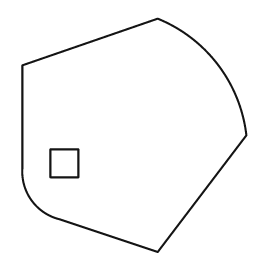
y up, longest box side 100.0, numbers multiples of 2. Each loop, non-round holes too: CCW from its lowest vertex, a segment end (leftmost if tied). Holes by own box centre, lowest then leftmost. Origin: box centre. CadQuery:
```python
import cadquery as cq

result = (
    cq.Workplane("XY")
    .moveTo(10.0, -50.0)
    .lineTo(48.0, 0.0)
    .threePointArc((36.0, 30.0), (10.0, 50.0))
    .lineTo(-48.0, 30.0)
    .lineTo(-48.0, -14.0)
    .threePointArc((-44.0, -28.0), (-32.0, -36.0))
    .close()
    .moveTo(-36.0, -18.0)
    .lineTo(-24.0, -18.0)
    .lineTo(-24.0, -6.0)
    .lineTo(-36.0, -6.0)
    .close()
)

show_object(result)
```